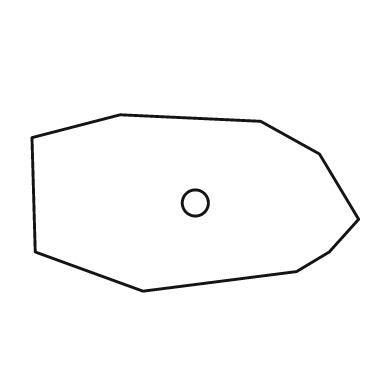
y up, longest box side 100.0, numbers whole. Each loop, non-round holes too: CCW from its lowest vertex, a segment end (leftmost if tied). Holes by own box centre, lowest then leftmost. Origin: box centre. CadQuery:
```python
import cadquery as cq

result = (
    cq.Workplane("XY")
    .moveTo(-16.0, -27.0)
    .lineTo(31.0, -21.0)
    .lineTo(41.0, -15.0)
    .lineTo(50.0, -5.0)
    .lineTo(38.0, 15.0)
    .lineTo(20.0, 25.0)
    .lineTo(-23.0, 27.0)
    .lineTo(-50.0, 20.0)
    .lineTo(-49.0, -15.0)
    .close()
    .moveTo(0.0, 0.0)
    .circle(4.0)
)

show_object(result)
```